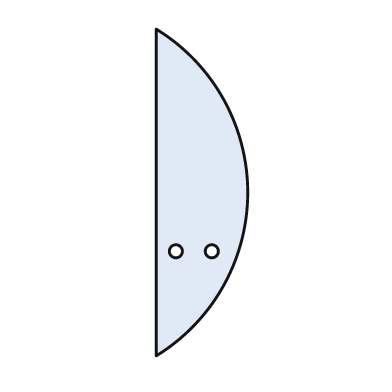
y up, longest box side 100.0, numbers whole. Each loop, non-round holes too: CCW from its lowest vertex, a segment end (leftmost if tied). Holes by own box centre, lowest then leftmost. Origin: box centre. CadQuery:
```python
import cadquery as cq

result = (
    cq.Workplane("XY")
    .moveTo(-14.0, -50.0)
    .threePointArc((14.0, 0.0), (-14.0, 50.0))
    .close()
    .moveTo(-8.0, -18.0)
    .circle(2.0)
    .moveTo(3.0, -18.0)
    .circle(2.0)
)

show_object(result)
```